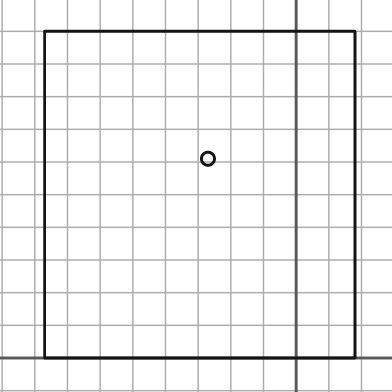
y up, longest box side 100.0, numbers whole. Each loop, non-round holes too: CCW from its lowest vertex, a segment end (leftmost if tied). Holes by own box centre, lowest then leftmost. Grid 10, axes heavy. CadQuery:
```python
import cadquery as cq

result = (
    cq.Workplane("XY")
    .moveTo(-77.0, 0.0)
    .lineTo(18.0, 0.0)
    .lineTo(18.0, 100.0)
    .lineTo(-77.0, 100.0)
    .close()
    .moveTo(-27.0, 61.0)
    .circle(2.0)
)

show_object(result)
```